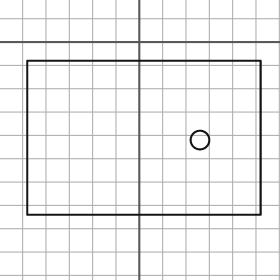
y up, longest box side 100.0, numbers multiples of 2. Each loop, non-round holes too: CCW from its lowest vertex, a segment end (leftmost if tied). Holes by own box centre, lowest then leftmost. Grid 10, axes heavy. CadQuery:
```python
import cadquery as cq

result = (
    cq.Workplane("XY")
    .moveTo(-48.0, -74.0)
    .lineTo(52.0, -74.0)
    .lineTo(52.0, -8.0)
    .lineTo(-48.0, -8.0)
    .close()
    .moveTo(26.0, -42.0)
    .circle(4.0)
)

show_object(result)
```